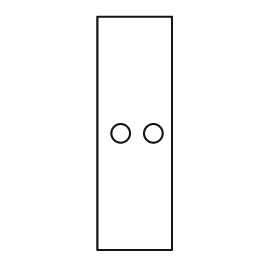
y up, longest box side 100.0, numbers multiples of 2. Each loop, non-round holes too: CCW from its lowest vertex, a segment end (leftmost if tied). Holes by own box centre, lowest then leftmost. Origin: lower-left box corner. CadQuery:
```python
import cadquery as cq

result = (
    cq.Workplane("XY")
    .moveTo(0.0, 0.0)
    .lineTo(32.0, 0.0)
    .lineTo(32.0, 100.0)
    .lineTo(0.0, 100.0)
    .close()
    .moveTo(10.0, 50.0)
    .circle(4.0)
    .moveTo(24.0, 50.0)
    .circle(4.0)
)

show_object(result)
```